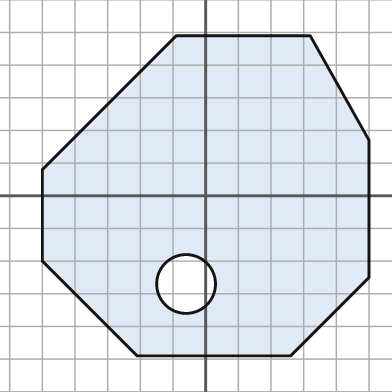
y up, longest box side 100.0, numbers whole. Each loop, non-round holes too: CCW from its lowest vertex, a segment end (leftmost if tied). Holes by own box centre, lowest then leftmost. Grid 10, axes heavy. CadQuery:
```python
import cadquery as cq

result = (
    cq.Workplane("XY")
    .moveTo(-21.0, -49.0)
    .lineTo(26.0, -49.0)
    .lineTo(50.0, -25.0)
    .lineTo(50.0, 17.0)
    .lineTo(32.0, 49.0)
    .lineTo(-9.0, 49.0)
    .lineTo(-50.0, 8.0)
    .lineTo(-50.0, -20.0)
    .close()
    .moveTo(-6.0, -27.0)
    .circle(9.0)
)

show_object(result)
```